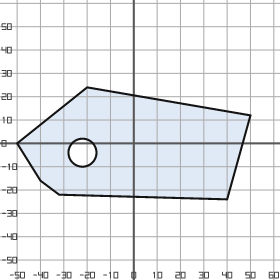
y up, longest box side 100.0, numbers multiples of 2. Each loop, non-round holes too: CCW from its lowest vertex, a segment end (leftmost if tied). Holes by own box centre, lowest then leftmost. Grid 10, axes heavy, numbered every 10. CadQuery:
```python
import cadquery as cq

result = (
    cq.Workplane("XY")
    .moveTo(40.0, -24.0)
    .lineTo(50.0, 12.0)
    .lineTo(-20.0, 24.0)
    .lineTo(-50.0, 0.0)
    .lineTo(-40.0, -16.0)
    .lineTo(-32.0, -22.0)
    .close()
    .moveTo(-22.0, -4.0)
    .circle(6.0)
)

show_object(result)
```